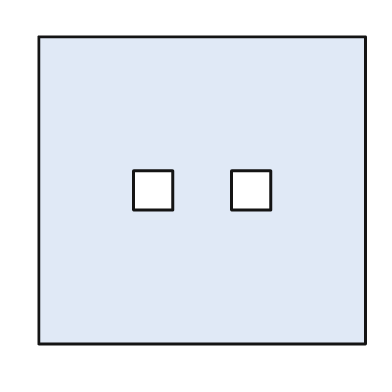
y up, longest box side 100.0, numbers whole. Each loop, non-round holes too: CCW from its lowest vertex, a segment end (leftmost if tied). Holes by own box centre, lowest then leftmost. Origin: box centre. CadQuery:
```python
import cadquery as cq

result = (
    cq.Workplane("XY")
    .moveTo(-50.0, -47.0)
    .lineTo(50.0, -47.0)
    .lineTo(50.0, 47.0)
    .lineTo(-50.0, 47.0)
    .close()
    .moveTo(-21.0, -6.0)
    .lineTo(-9.0, -6.0)
    .lineTo(-9.0, 6.0)
    .lineTo(-21.0, 6.0)
    .close()
    .moveTo(9.0, -6.0)
    .lineTo(21.0, -6.0)
    .lineTo(21.0, 6.0)
    .lineTo(9.0, 6.0)
    .close()
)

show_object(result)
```